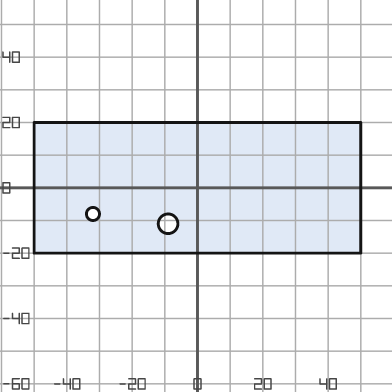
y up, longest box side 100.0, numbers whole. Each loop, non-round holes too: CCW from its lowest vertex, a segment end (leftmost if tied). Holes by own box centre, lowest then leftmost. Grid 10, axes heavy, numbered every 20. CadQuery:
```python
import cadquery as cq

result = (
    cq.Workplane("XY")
    .moveTo(-50.0, -20.0)
    .lineTo(50.0, -20.0)
    .lineTo(50.0, 20.0)
    .lineTo(-50.0, 20.0)
    .close()
    .moveTo(-9.0, -11.0)
    .circle(3.0)
    .moveTo(-32.0, -8.0)
    .circle(2.0)
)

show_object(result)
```